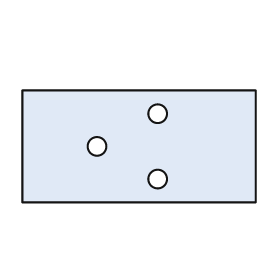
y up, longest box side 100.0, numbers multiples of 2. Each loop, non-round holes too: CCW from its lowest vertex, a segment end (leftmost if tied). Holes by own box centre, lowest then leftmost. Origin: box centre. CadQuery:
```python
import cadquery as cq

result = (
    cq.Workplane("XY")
    .moveTo(-50.0, -24.0)
    .lineTo(50.0, -24.0)
    .lineTo(50.0, 24.0)
    .lineTo(-50.0, 24.0)
    .close()
    .moveTo(8.0, -14.0)
    .circle(4.0)
    .moveTo(-18.0, 0.0)
    .circle(4.0)
    .moveTo(8.0, 14.0)
    .circle(4.0)
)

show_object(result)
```